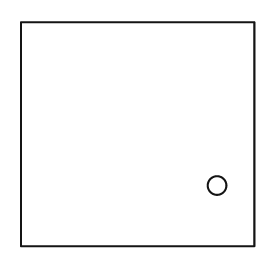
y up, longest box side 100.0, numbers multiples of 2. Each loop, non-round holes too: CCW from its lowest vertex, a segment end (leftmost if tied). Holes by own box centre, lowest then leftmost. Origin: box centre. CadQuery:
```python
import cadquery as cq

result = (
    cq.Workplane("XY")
    .moveTo(-50.0, -48.0)
    .lineTo(50.0, -48.0)
    .lineTo(50.0, 48.0)
    .lineTo(-50.0, 48.0)
    .close()
    .moveTo(34.0, -22.0)
    .circle(4.0)
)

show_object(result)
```